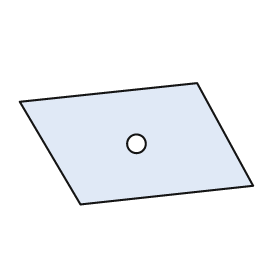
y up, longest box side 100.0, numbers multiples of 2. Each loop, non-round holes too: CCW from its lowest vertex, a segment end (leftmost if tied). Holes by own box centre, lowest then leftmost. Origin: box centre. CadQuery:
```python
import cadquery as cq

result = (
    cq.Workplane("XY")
    .moveTo(-24.0, -26.0)
    .lineTo(50.0, -18.0)
    .lineTo(26.0, 26.0)
    .lineTo(-50.0, 18.0)
    .close()
    .moveTo(0.0, 0.0)
    .circle(4.0)
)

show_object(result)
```